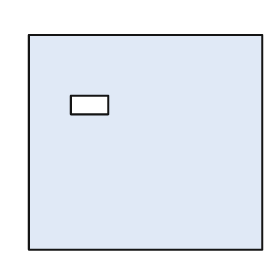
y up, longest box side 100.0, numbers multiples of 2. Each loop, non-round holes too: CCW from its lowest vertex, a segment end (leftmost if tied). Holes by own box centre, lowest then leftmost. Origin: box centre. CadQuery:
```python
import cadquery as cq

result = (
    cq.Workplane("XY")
    .moveTo(-50.0, -46.0)
    .lineTo(50.0, -46.0)
    .lineTo(50.0, 46.0)
    .lineTo(-50.0, 46.0)
    .close()
    .moveTo(-32.0, 12.0)
    .lineTo(-16.0, 12.0)
    .lineTo(-16.0, 20.0)
    .lineTo(-32.0, 20.0)
    .close()
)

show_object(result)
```